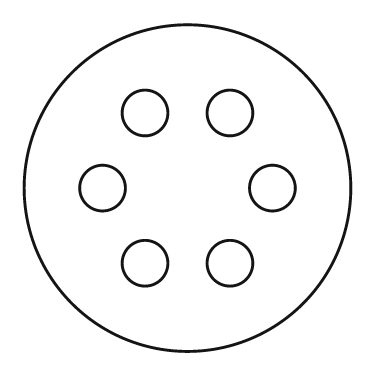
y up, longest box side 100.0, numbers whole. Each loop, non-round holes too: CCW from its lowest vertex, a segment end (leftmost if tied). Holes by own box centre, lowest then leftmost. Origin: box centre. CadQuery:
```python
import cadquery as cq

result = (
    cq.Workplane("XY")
    .moveTo(0.0, 0.0)
    .circle(50.0)
    .moveTo(-13.0, -23.0)
    .circle(7.0)
    .moveTo(13.0, -23.0)
    .circle(7.0)
    .moveTo(-26.0, 0.0)
    .circle(7.0)
    .moveTo(26.0, 0.0)
    .circle(7.0)
    .moveTo(-13.0, 23.0)
    .circle(7.0)
    .moveTo(13.0, 23.0)
    .circle(7.0)
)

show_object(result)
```